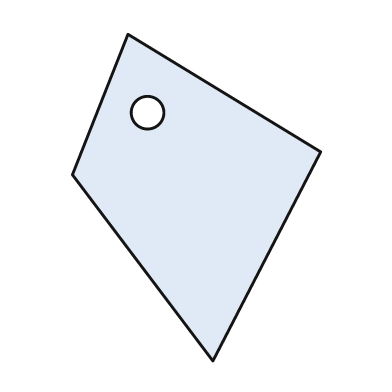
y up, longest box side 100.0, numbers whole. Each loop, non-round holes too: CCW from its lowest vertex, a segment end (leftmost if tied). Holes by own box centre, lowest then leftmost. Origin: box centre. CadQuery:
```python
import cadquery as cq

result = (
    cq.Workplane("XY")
    .moveTo(5.0, -50.0)
    .lineTo(38.0, 14.0)
    .lineTo(-21.0, 50.0)
    .lineTo(-38.0, 7.0)
    .close()
    .moveTo(-15.0, 26.0)
    .circle(5.0)
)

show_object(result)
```